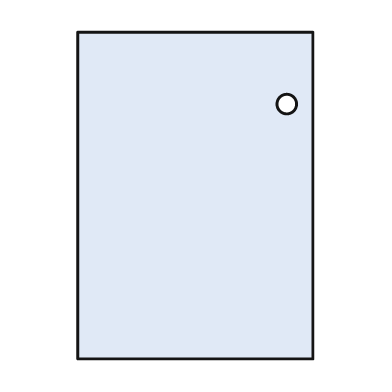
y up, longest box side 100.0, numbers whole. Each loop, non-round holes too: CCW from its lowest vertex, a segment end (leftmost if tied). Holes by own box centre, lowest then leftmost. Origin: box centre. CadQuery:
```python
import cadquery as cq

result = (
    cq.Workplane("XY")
    .moveTo(-36.0, -50.0)
    .lineTo(36.0, -50.0)
    .lineTo(36.0, 50.0)
    .lineTo(-36.0, 50.0)
    .close()
    .moveTo(28.0, 28.0)
    .circle(3.0)
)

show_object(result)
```